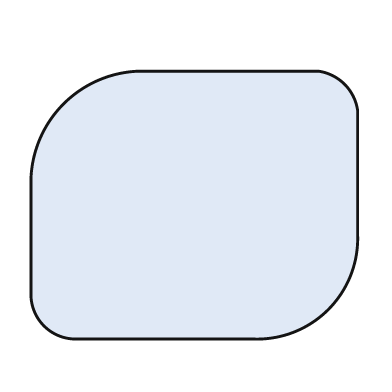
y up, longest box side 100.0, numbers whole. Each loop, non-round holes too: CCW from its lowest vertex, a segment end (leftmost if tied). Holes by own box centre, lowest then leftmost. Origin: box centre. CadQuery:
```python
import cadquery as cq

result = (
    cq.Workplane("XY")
    .moveTo(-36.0, -41.0)
    .lineTo(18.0, -41.0)
    .threePointArc((41.0, -32.0), (50.0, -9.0))
    .lineTo(50.0, 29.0)
    .threePointArc((46.0, 37.0), (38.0, 41.0))
    .lineTo(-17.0, 41.0)
    .threePointArc((-40.0, 31.0), (-50.0, 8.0))
    .lineTo(-50.0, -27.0)
    .threePointArc((-46.0, -37.0), (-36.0, -41.0))
    .close()
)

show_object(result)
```